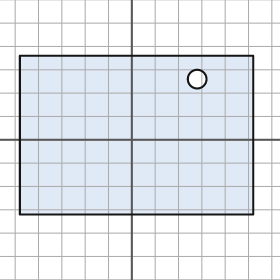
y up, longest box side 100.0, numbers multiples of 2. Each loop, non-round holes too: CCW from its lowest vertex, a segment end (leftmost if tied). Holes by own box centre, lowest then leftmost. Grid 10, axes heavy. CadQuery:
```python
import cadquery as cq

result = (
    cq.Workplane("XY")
    .moveTo(-48.0, -32.0)
    .lineTo(52.0, -32.0)
    .lineTo(52.0, 36.0)
    .lineTo(-48.0, 36.0)
    .close()
    .moveTo(28.0, 26.0)
    .circle(4.0)
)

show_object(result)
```